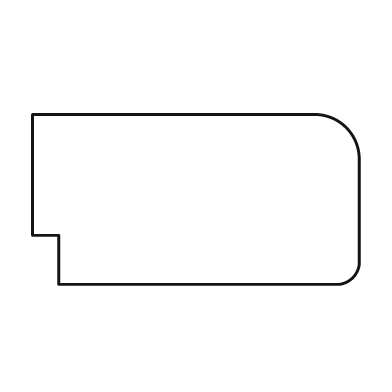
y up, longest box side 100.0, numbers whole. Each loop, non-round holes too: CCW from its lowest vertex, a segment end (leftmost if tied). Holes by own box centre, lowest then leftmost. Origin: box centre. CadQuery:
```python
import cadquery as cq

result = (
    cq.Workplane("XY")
    .moveTo(-42.0, -26.0)
    .lineTo(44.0, -26.0)
    .threePointArc((48.0, -24.0), (50.0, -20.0))
    .lineTo(50.0, 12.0)
    .threePointArc((46.0, 22.0), (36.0, 26.0))
    .lineTo(-50.0, 26.0)
    .lineTo(-50.0, -11.0)
    .lineTo(-42.0, -11.0)
    .close()
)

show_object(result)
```